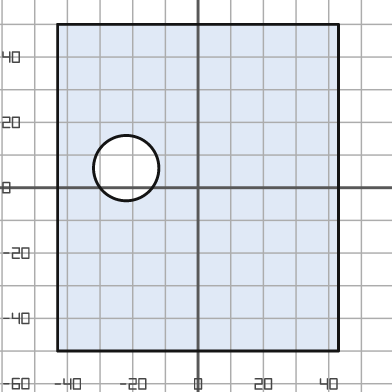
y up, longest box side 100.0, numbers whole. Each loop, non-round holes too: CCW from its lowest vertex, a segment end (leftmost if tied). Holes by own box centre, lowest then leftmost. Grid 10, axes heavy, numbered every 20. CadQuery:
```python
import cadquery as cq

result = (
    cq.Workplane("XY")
    .moveTo(-43.0, -50.0)
    .lineTo(43.0, -50.0)
    .lineTo(43.0, 50.0)
    .lineTo(-43.0, 50.0)
    .close()
    .moveTo(-22.0, 6.0)
    .circle(10.0)
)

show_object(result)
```